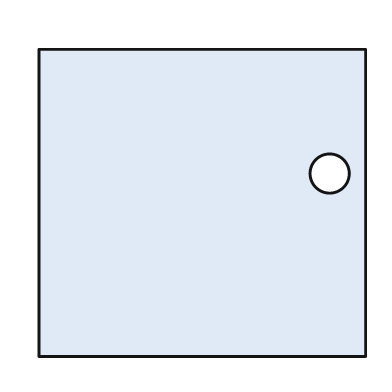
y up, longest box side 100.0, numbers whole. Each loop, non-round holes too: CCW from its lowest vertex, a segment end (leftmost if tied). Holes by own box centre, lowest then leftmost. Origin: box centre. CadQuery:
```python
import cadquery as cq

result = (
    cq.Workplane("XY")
    .moveTo(-50.0, -47.0)
    .lineTo(50.0, -47.0)
    .lineTo(50.0, 47.0)
    .lineTo(-50.0, 47.0)
    .close()
    .moveTo(39.0, 9.0)
    .circle(6.0)
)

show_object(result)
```